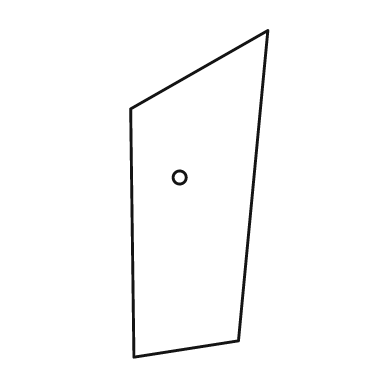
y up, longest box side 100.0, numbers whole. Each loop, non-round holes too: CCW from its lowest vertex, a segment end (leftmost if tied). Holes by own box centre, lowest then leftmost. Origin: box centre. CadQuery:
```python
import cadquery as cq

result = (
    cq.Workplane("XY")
    .moveTo(-20.0, -50.0)
    .lineTo(12.0, -45.0)
    .lineTo(21.0, 50.0)
    .lineTo(-21.0, 26.0)
    .close()
    .moveTo(-6.0, 5.0)
    .circle(2.0)
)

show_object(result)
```